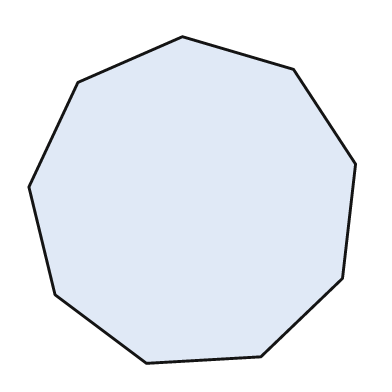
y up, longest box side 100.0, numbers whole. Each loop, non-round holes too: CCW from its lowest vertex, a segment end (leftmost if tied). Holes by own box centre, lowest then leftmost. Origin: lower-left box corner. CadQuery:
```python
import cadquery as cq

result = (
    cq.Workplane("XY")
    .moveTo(36.0, 0.0)
    .lineTo(71.0, 2.0)
    .lineTo(96.0, 26.0)
    .lineTo(100.0, 61.0)
    .lineTo(81.0, 90.0)
    .lineTo(47.0, 100.0)
    .lineTo(15.0, 86.0)
    .lineTo(0.0, 54.0)
    .lineTo(8.0, 21.0)
    .close()
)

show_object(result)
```